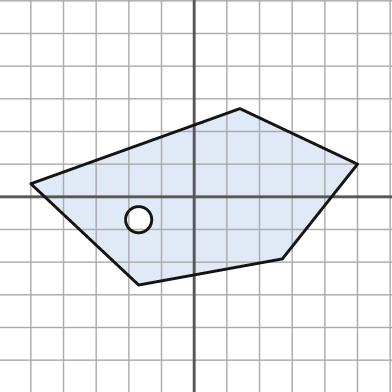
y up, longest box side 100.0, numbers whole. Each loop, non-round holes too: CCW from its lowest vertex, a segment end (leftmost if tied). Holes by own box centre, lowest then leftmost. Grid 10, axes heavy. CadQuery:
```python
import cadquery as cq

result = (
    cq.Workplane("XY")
    .moveTo(-17.0, -27.0)
    .lineTo(27.0, -19.0)
    .lineTo(50.0, 10.0)
    .lineTo(14.0, 27.0)
    .lineTo(-50.0, 4.0)
    .close()
    .moveTo(-17.0, -7.0)
    .circle(4.0)
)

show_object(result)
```